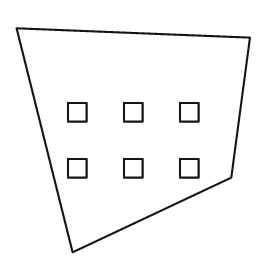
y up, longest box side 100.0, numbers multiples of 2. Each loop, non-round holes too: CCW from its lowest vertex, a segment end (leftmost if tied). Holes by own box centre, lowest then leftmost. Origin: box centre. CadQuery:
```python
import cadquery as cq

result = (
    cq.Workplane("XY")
    .moveTo(-26.0, -48.0)
    .lineTo(42.0, -16.0)
    .lineTo(50.0, 44.0)
    .lineTo(-50.0, 48.0)
    .close()
    .moveTo(-28.0, -16.0)
    .lineTo(-20.0, -16.0)
    .lineTo(-20.0, -8.0)
    .lineTo(-28.0, -8.0)
    .close()
    .moveTo(-4.0, -16.0)
    .lineTo(4.0, -16.0)
    .lineTo(4.0, -8.0)
    .lineTo(-4.0, -8.0)
    .close()
    .moveTo(20.0, -16.0)
    .lineTo(28.0, -16.0)
    .lineTo(28.0, -8.0)
    .lineTo(20.0, -8.0)
    .close()
    .moveTo(-28.0, 8.0)
    .lineTo(-20.0, 8.0)
    .lineTo(-20.0, 16.0)
    .lineTo(-28.0, 16.0)
    .close()
    .moveTo(-4.0, 8.0)
    .lineTo(4.0, 8.0)
    .lineTo(4.0, 16.0)
    .lineTo(-4.0, 16.0)
    .close()
    .moveTo(20.0, 8.0)
    .lineTo(28.0, 8.0)
    .lineTo(28.0, 16.0)
    .lineTo(20.0, 16.0)
    .close()
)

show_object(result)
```